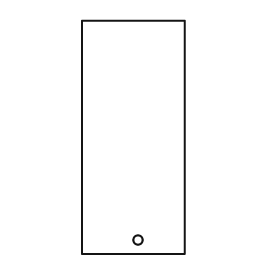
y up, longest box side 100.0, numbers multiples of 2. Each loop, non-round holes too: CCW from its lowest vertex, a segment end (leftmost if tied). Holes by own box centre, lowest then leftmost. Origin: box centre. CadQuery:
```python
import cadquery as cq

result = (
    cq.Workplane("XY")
    .moveTo(-22.0, -50.0)
    .lineTo(22.0, -50.0)
    .lineTo(22.0, 50.0)
    .lineTo(-22.0, 50.0)
    .close()
    .moveTo(2.0, -44.0)
    .circle(2.0)
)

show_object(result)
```